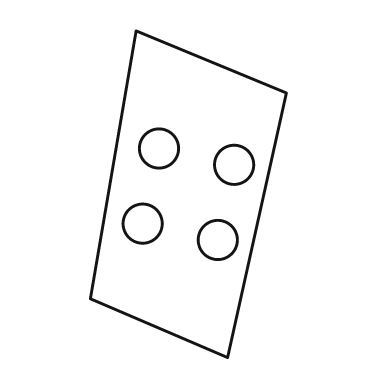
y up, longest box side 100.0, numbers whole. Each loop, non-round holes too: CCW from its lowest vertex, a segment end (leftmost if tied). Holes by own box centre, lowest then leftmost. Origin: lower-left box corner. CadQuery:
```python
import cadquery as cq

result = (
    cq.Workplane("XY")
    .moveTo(42.0, 0.0)
    .lineTo(60.0, 81.0)
    .lineTo(14.0, 100.0)
    .lineTo(0.0, 18.0)
    .close()
    .moveTo(39.0, 36.0)
    .circle(6.0)
    .moveTo(16.0, 41.0)
    .circle(6.0)
    .moveTo(44.0, 59.0)
    .circle(6.0)
    .moveTo(21.0, 64.0)
    .circle(6.0)
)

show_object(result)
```